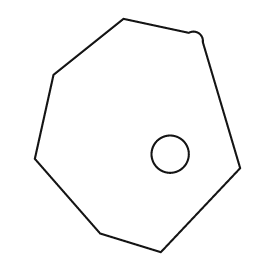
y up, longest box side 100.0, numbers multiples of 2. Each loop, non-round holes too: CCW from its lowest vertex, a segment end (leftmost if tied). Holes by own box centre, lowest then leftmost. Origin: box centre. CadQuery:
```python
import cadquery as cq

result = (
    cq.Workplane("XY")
    .moveTo(10.0, -50.0)
    .lineTo(44.0, -14.0)
    .lineTo(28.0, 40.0)
    .threePointArc((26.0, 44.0), (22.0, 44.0))
    .lineTo(-6.0, 50.0)
    .lineTo(-36.0, 26.0)
    .lineTo(-44.0, -10.0)
    .lineTo(-16.0, -42.0)
    .close()
    .moveTo(14.0, -8.0)
    .circle(8.0)
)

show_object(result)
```